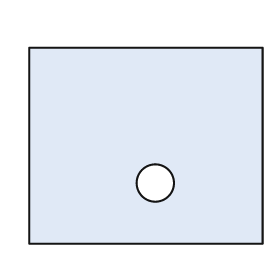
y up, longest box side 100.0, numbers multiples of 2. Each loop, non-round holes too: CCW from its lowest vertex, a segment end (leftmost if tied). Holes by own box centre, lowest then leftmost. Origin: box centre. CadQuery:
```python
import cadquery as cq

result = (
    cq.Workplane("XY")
    .moveTo(-50.0, -42.0)
    .lineTo(50.0, -42.0)
    .lineTo(50.0, 42.0)
    .lineTo(-50.0, 42.0)
    .close()
    .moveTo(4.0, -16.0)
    .circle(8.0)
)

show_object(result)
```